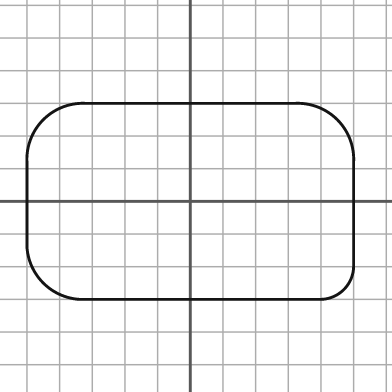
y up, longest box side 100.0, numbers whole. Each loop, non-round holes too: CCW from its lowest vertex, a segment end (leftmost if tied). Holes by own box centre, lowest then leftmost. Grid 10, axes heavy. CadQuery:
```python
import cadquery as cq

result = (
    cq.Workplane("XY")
    .moveTo(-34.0, -30.0)
    .lineTo(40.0, -30.0)
    .threePointArc((47.0, -27.0), (50.0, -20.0))
    .lineTo(50.0, 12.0)
    .threePointArc((45.0, 25.0), (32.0, 30.0))
    .lineTo(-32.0, 30.0)
    .threePointArc((-45.0, 25.0), (-50.0, 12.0))
    .lineTo(-50.0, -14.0)
    .threePointArc((-45.0, -25.0), (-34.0, -30.0))
    .close()
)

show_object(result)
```